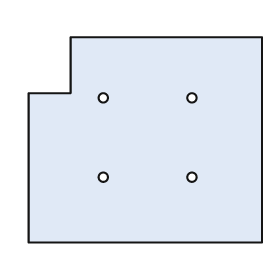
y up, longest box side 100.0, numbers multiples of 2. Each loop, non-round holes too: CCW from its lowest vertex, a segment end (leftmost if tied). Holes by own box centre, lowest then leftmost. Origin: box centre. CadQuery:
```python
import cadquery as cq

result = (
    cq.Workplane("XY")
    .moveTo(-50.0, -44.0)
    .lineTo(50.0, -44.0)
    .lineTo(50.0, 44.0)
    .lineTo(-32.0, 44.0)
    .lineTo(-32.0, 20.0)
    .lineTo(-50.0, 20.0)
    .close()
    .moveTo(-18.0, -16.0)
    .circle(2.0)
    .moveTo(20.0, -16.0)
    .circle(2.0)
    .moveTo(-18.0, 18.0)
    .circle(2.0)
    .moveTo(20.0, 18.0)
    .circle(2.0)
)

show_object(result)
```